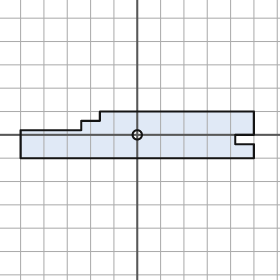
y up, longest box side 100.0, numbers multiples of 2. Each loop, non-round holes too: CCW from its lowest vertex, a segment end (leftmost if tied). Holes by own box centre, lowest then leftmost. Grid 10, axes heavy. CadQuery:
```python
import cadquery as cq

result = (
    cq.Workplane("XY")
    .moveTo(-50.0, -10.0)
    .lineTo(50.0, -10.0)
    .lineTo(50.0, -4.0)
    .lineTo(42.0, -4.0)
    .lineTo(42.0, 0.0)
    .lineTo(50.0, 0.0)
    .lineTo(50.0, 10.0)
    .lineTo(-16.0, 10.0)
    .lineTo(-16.0, 6.0)
    .lineTo(-24.0, 6.0)
    .lineTo(-24.0, 2.0)
    .lineTo(-50.0, 2.0)
    .close()
    .moveTo(0.0, 0.0)
    .circle(2.0)
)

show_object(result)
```